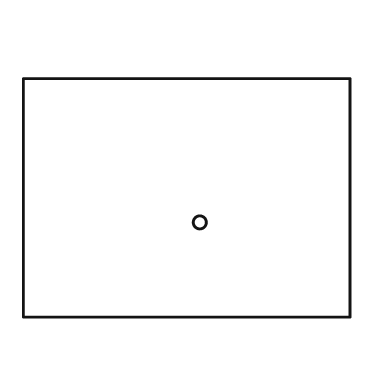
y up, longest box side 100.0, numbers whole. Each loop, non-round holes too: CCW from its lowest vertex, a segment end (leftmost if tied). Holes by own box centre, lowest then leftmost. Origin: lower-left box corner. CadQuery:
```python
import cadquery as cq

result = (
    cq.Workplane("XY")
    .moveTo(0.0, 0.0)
    .lineTo(100.0, 0.0)
    .lineTo(100.0, 73.0)
    .lineTo(0.0, 73.0)
    .close()
    .moveTo(54.0, 29.0)
    .circle(2.0)
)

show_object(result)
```